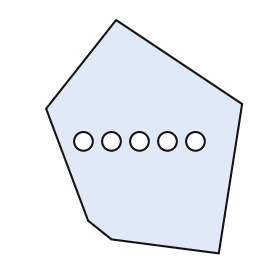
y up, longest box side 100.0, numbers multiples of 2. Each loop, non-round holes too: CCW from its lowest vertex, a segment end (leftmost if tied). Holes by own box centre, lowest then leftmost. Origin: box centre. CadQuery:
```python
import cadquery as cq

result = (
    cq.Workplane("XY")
    .moveTo(32.0, -50.0)
    .lineTo(42.0, 14.0)
    .lineTo(-12.0, 50.0)
    .lineTo(-42.0, 12.0)
    .lineTo(-24.0, -36.0)
    .lineTo(-14.0, -44.0)
    .close()
    .moveTo(-26.0, -2.0)
    .circle(4.0)
    .moveTo(-14.0, -2.0)
    .circle(4.0)
    .moveTo(-2.0, -2.0)
    .circle(4.0)
    .moveTo(10.0, -2.0)
    .circle(4.0)
    .moveTo(22.0, -2.0)
    .circle(4.0)
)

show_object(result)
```